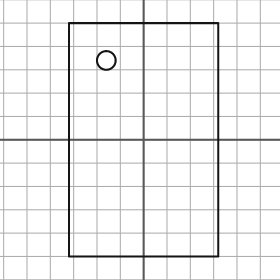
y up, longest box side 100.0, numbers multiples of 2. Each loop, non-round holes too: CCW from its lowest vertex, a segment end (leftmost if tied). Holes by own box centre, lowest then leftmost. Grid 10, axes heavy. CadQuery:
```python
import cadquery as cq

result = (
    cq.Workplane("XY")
    .moveTo(-32.0, -50.0)
    .lineTo(32.0, -50.0)
    .lineTo(32.0, 50.0)
    .lineTo(-32.0, 50.0)
    .close()
    .moveTo(-16.0, 34.0)
    .circle(4.0)
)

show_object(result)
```